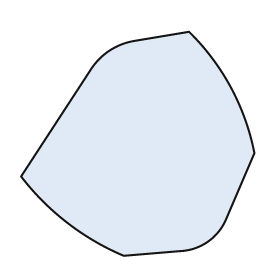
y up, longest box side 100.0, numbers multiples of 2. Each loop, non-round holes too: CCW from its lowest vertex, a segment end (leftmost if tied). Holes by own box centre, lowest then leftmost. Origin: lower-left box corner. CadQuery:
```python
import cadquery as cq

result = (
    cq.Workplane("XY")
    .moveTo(44.0, 0.0)
    .lineTo(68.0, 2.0)
    .threePointArc((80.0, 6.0), (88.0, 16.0))
    .lineTo(100.0, 44.0)
    .threePointArc((90.0, 72.0), (72.0, 96.0))
    .lineTo(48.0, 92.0)
    .threePointArc((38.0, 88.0), (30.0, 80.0))
    .lineTo(0.0, 34.0)
    .threePointArc((20.0, 14.0), (44.0, 0.0))
    .close()
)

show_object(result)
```